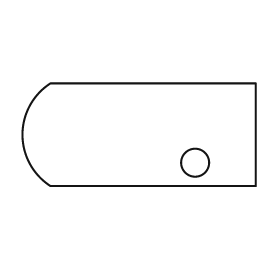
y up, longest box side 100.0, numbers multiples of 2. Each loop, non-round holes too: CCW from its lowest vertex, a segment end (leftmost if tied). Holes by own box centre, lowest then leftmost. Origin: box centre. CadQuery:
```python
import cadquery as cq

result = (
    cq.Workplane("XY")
    .moveTo(-38.0, -22.0)
    .lineTo(50.0, -22.0)
    .lineTo(50.0, 22.0)
    .lineTo(-38.0, 22.0)
    .threePointArc((-50.0, 0.0), (-38.0, -22.0))
    .close()
    .moveTo(24.0, -12.0)
    .circle(6.0)
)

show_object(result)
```